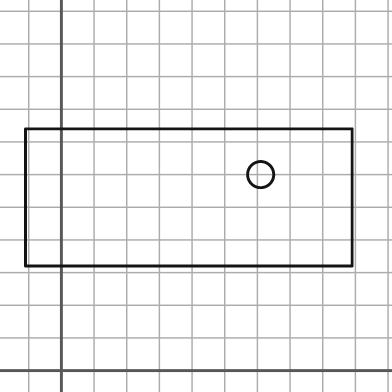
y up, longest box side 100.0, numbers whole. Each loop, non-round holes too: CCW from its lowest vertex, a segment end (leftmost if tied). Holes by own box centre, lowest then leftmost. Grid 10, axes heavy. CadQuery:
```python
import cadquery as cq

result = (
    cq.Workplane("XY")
    .moveTo(-11.0, 32.0)
    .lineTo(89.0, 32.0)
    .lineTo(89.0, 74.0)
    .lineTo(-11.0, 74.0)
    .close()
    .moveTo(61.0, 60.0)
    .circle(4.0)
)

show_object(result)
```